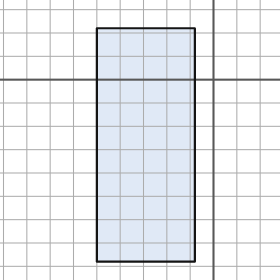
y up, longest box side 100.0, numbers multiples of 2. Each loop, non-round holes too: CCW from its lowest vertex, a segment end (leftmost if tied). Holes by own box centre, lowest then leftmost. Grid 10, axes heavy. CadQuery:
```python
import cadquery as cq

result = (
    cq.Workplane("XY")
    .moveTo(-50.0, -78.0)
    .lineTo(-8.0, -78.0)
    .lineTo(-8.0, 22.0)
    .lineTo(-50.0, 22.0)
    .close()
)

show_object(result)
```